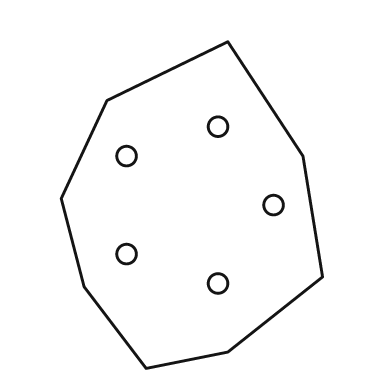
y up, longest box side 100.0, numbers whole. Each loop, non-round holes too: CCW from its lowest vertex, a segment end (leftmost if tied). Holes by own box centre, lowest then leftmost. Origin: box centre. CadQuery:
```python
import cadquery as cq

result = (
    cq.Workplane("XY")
    .moveTo(-14.0, -50.0)
    .lineTo(11.0, -45.0)
    .lineTo(40.0, -22.0)
    .lineTo(34.0, 15.0)
    .lineTo(11.0, 50.0)
    .lineTo(-26.0, 32.0)
    .lineTo(-40.0, 2.0)
    .lineTo(-33.0, -25.0)
    .close()
    .moveTo(8.0, -24.0)
    .circle(3.0)
    .moveTo(-20.0, -15.0)
    .circle(3.0)
    .moveTo(25.0, 0.0)
    .circle(3.0)
    .moveTo(-20.0, 15.0)
    .circle(3.0)
    .moveTo(8.0, 24.0)
    .circle(3.0)
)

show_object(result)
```